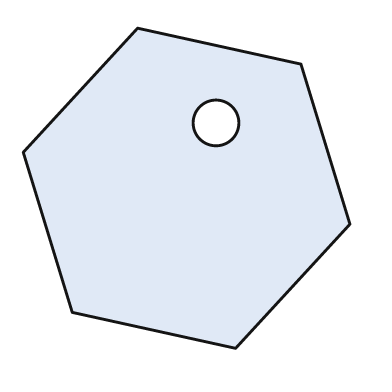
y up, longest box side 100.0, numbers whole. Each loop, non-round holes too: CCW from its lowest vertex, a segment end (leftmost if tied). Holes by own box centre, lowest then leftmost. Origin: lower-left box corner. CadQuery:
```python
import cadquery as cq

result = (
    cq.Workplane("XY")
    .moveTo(65.0, 0.0)
    .lineTo(100.0, 38.0)
    .lineTo(85.0, 87.0)
    .lineTo(35.0, 98.0)
    .lineTo(0.0, 60.0)
    .lineTo(15.0, 11.0)
    .close()
    .moveTo(59.0, 69.0)
    .circle(7.0)
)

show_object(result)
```